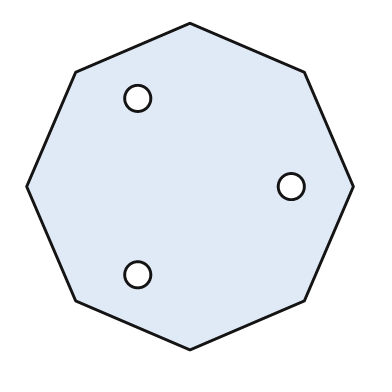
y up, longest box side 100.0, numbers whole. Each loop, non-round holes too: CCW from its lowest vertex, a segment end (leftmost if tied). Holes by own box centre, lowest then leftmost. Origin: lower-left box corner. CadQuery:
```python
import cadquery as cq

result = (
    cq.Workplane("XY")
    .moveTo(50.0, 0.0)
    .lineTo(85.0, 15.0)
    .lineTo(100.0, 50.0)
    .lineTo(85.0, 85.0)
    .lineTo(50.0, 100.0)
    .lineTo(15.0, 85.0)
    .lineTo(0.0, 50.0)
    .lineTo(15.0, 15.0)
    .close()
    .moveTo(34.0, 23.0)
    .circle(4.0)
    .moveTo(81.0, 50.0)
    .circle(4.0)
    .moveTo(34.0, 77.0)
    .circle(4.0)
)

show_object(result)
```